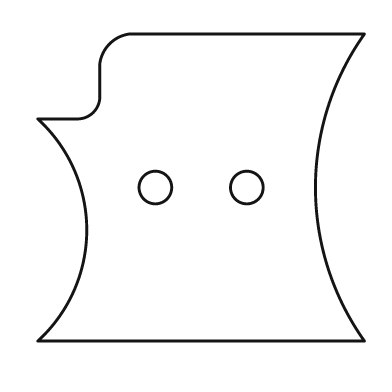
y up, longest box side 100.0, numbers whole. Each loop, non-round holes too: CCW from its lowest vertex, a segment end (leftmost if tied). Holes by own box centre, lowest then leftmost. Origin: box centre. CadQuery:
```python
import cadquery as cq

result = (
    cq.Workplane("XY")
    .moveTo(-50.0, -47.0)
    .lineTo(50.0, -47.0)
    .threePointArc((35.0, 0.0), (50.0, 47.0))
    .lineTo(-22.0, 47.0)
    .threePointArc((-28.0, 44.0), (-31.0, 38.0))
    .lineTo(-31.0, 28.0)
    .threePointArc((-33.0, 23.0), (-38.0, 21.0))
    .lineTo(-50.0, 21.0)
    .threePointArc((-35.0, -13.0), (-50.0, -47.0))
    .close()
    .moveTo(-14.0, 0.0)
    .circle(5.0)
    .moveTo(14.0, 0.0)
    .circle(5.0)
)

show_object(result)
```